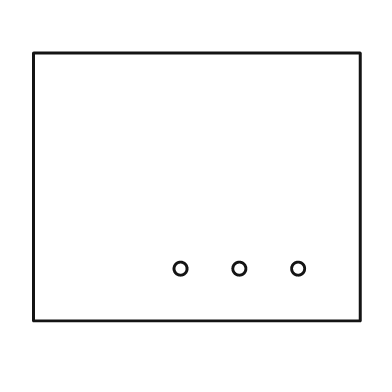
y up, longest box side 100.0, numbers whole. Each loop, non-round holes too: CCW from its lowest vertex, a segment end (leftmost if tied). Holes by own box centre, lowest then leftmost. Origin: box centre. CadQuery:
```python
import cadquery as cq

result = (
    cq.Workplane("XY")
    .moveTo(-50.0, -41.0)
    .lineTo(50.0, -41.0)
    .lineTo(50.0, 41.0)
    .lineTo(-50.0, 41.0)
    .close()
    .moveTo(-5.0, -25.0)
    .circle(2.0)
    .moveTo(13.0, -25.0)
    .circle(2.0)
    .moveTo(31.0, -25.0)
    .circle(2.0)
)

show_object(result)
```